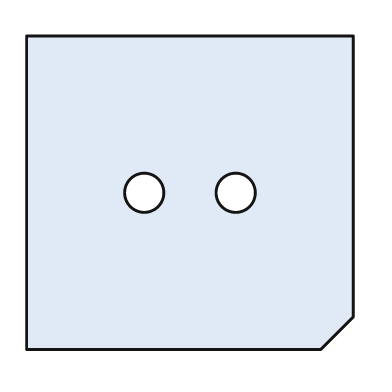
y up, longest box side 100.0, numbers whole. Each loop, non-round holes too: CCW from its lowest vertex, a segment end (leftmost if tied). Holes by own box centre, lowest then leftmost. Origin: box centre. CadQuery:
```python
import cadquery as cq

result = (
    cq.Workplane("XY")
    .moveTo(-50.0, -48.0)
    .lineTo(40.0, -48.0)
    .lineTo(50.0, -38.0)
    .lineTo(50.0, 48.0)
    .lineTo(-50.0, 48.0)
    .close()
    .moveTo(-14.0, 0.0)
    .circle(6.0)
    .moveTo(14.0, 0.0)
    .circle(6.0)
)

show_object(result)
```